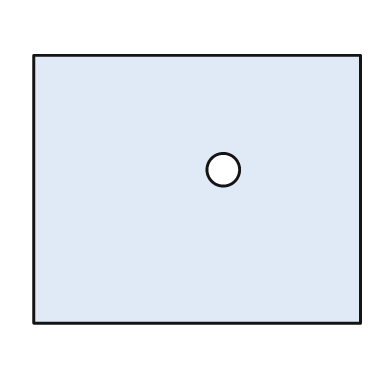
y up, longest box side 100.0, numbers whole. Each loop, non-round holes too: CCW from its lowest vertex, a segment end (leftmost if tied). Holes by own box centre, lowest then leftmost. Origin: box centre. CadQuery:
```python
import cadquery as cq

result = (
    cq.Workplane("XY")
    .moveTo(-50.0, -41.0)
    .lineTo(50.0, -41.0)
    .lineTo(50.0, 41.0)
    .lineTo(-50.0, 41.0)
    .close()
    .moveTo(8.0, 6.0)
    .circle(5.0)
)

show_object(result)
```